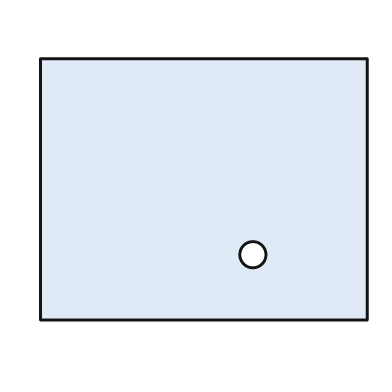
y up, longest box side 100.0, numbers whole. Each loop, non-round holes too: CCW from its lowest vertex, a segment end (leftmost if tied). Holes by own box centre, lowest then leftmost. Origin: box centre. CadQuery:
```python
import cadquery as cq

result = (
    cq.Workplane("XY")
    .moveTo(-50.0, -40.0)
    .lineTo(50.0, -40.0)
    .lineTo(50.0, 40.0)
    .lineTo(-50.0, 40.0)
    .close()
    .moveTo(15.0, -20.0)
    .circle(4.0)
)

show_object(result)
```